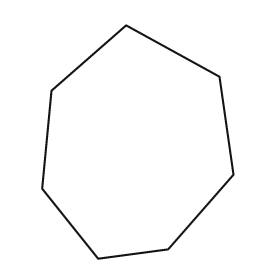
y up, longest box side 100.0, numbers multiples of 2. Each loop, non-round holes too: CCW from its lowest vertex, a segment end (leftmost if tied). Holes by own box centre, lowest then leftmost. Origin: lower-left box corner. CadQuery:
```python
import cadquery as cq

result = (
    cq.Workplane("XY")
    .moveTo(24.0, 0.0)
    .lineTo(54.0, 4.0)
    .lineTo(82.0, 36.0)
    .lineTo(76.0, 78.0)
    .lineTo(36.0, 100.0)
    .lineTo(4.0, 72.0)
    .lineTo(0.0, 30.0)
    .close()
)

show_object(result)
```